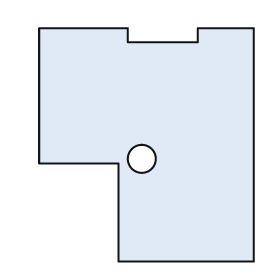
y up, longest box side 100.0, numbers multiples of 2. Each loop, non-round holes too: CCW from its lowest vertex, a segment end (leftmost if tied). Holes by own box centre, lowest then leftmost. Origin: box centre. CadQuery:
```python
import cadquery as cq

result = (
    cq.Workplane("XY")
    .moveTo(-12.0, -50.0)
    .lineTo(46.0, -50.0)
    .lineTo(46.0, 50.0)
    .lineTo(22.0, 50.0)
    .lineTo(22.0, 44.0)
    .lineTo(-8.0, 44.0)
    .lineTo(-8.0, 50.0)
    .lineTo(-46.0, 50.0)
    .lineTo(-46.0, -8.0)
    .lineTo(-12.0, -8.0)
    .close()
    .moveTo(-2.0, -6.0)
    .circle(6.0)
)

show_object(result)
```